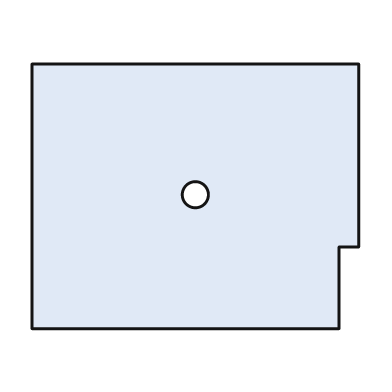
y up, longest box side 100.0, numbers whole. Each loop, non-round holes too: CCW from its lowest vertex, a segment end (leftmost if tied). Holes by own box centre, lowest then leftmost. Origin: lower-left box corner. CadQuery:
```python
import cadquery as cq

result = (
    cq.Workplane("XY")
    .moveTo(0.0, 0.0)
    .lineTo(94.0, 0.0)
    .lineTo(94.0, 25.0)
    .lineTo(100.0, 25.0)
    .lineTo(100.0, 81.0)
    .lineTo(0.0, 81.0)
    .close()
    .moveTo(50.0, 41.0)
    .circle(4.0)
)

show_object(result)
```